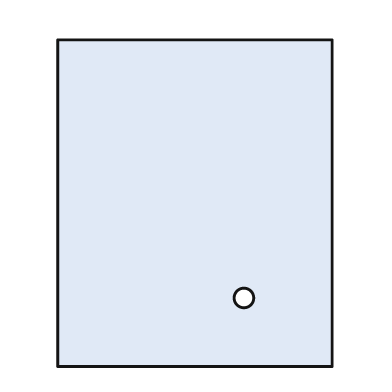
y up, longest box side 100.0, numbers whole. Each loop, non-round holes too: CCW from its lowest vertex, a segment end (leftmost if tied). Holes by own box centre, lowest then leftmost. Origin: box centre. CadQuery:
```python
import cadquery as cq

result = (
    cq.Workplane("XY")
    .moveTo(-42.0, -50.0)
    .lineTo(42.0, -50.0)
    .lineTo(42.0, 50.0)
    .lineTo(-42.0, 50.0)
    .close()
    .moveTo(15.0, -29.0)
    .circle(3.0)
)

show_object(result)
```